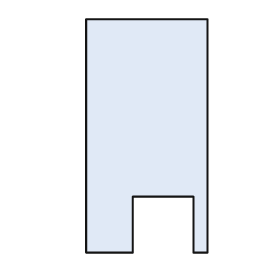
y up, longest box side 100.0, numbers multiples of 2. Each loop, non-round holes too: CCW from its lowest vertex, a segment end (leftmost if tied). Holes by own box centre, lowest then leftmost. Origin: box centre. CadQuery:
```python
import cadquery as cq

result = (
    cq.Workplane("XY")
    .moveTo(-26.0, -50.0)
    .lineTo(-6.0, -50.0)
    .lineTo(-6.0, -26.0)
    .lineTo(20.0, -26.0)
    .lineTo(20.0, -50.0)
    .lineTo(26.0, -50.0)
    .lineTo(26.0, 50.0)
    .lineTo(-26.0, 50.0)
    .close()
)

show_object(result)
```